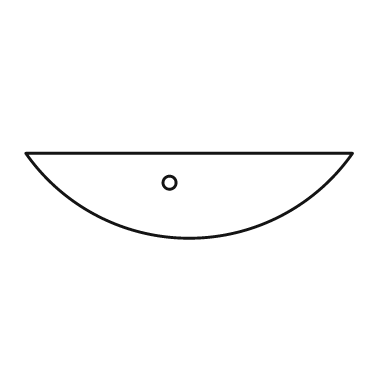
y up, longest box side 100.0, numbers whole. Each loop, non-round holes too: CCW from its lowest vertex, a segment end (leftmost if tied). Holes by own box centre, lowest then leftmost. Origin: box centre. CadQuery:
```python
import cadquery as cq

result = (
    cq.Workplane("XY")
    .moveTo(-50.0, 13.0)
    .threePointArc((0.0, -13.0), (50.0, 13.0))
    .close()
    .moveTo(-6.0, 4.0)
    .circle(2.0)
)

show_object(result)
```